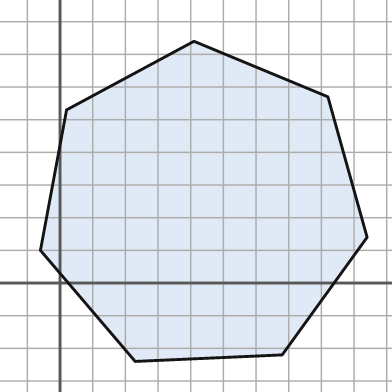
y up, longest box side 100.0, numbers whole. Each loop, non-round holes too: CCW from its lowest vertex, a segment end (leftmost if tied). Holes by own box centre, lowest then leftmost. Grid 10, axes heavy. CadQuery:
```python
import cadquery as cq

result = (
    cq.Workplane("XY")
    .moveTo(23.0, -24.0)
    .lineTo(68.0, -22.0)
    .lineTo(94.0, 14.0)
    .lineTo(82.0, 57.0)
    .lineTo(41.0, 74.0)
    .lineTo(2.0, 53.0)
    .lineTo(-6.0, 10.0)
    .close()
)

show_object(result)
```